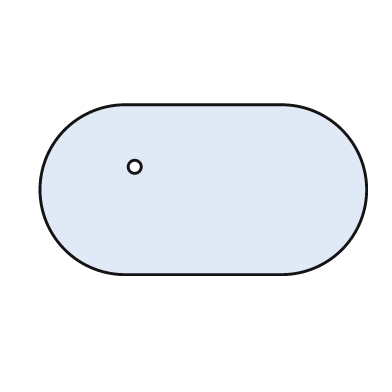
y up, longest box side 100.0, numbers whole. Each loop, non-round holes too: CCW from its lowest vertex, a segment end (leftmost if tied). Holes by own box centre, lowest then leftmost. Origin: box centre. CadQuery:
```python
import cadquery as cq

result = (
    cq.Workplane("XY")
    .moveTo(-24.0, -26.0)
    .lineTo(24.0, -26.0)
    .threePointArc((50.0, 0.0), (24.0, 26.0))
    .lineTo(-24.0, 26.0)
    .threePointArc((-50.0, 0.0), (-24.0, -26.0))
    .close()
    .moveTo(-21.0, 7.0)
    .circle(2.0)
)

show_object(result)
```